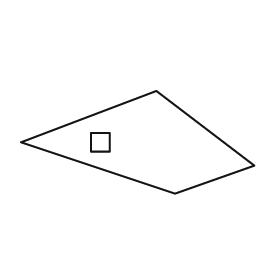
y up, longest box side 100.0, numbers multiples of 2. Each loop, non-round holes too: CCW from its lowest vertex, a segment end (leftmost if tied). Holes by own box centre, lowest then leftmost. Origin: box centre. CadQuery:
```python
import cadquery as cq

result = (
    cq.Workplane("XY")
    .moveTo(16.0, -22.0)
    .lineTo(50.0, -10.0)
    .lineTo(8.0, 22.0)
    .lineTo(-50.0, 0.0)
    .close()
    .moveTo(-20.0, -4.0)
    .lineTo(-12.0, -4.0)
    .lineTo(-12.0, 4.0)
    .lineTo(-20.0, 4.0)
    .close()
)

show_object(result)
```